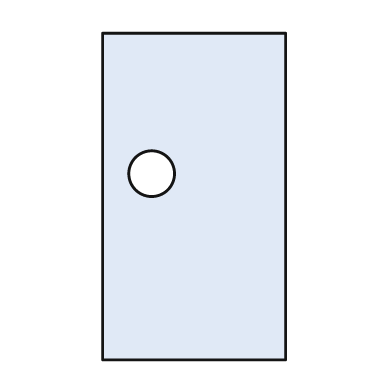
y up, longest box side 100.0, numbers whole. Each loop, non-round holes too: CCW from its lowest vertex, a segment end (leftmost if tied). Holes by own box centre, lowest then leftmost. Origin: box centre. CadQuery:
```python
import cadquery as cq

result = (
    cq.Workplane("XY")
    .moveTo(-28.0, -50.0)
    .lineTo(28.0, -50.0)
    .lineTo(28.0, 50.0)
    .lineTo(-28.0, 50.0)
    .close()
    .moveTo(-13.0, 7.0)
    .circle(7.0)
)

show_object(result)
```